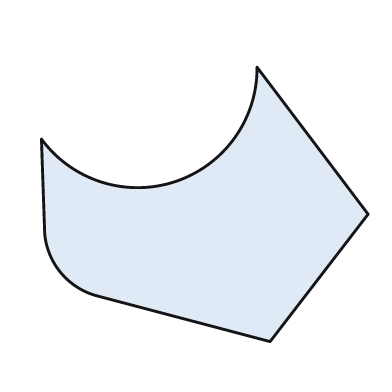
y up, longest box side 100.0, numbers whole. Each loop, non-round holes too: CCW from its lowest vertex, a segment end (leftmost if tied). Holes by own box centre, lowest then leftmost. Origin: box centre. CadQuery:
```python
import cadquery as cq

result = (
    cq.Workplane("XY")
    .moveTo(20.0, -42.0)
    .lineTo(50.0, -3.0)
    .lineTo(16.0, 42.0)
    .threePointArc((-9.0, 7.0), (-50.0, 20.0))
    .lineTo(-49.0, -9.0)
    .threePointArc((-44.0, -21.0), (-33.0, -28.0))
    .close()
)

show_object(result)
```